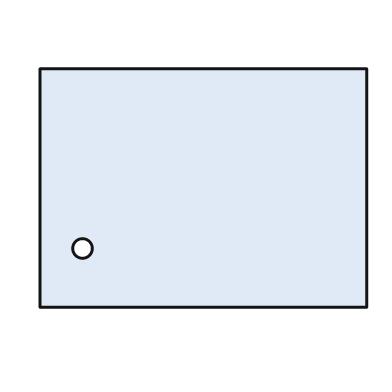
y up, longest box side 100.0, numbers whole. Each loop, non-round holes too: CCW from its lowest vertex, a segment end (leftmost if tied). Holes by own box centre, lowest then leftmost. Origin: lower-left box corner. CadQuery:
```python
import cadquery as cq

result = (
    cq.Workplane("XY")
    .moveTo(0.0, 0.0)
    .lineTo(100.0, 0.0)
    .lineTo(100.0, 73.0)
    .lineTo(0.0, 73.0)
    .close()
    .moveTo(13.0, 18.0)
    .circle(3.0)
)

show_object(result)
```